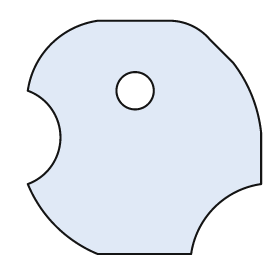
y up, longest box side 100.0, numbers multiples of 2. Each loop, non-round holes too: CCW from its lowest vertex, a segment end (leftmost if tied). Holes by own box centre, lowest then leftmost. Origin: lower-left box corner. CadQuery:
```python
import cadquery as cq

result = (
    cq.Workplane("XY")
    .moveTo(30.0, 0.0)
    .lineTo(70.0, 0.0)
    .threePointArc((80.0, 20.0), (100.0, 30.0))
    .lineTo(100.0, 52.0)
    .threePointArc((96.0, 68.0), (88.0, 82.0))
    .lineTo(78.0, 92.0)
    .threePointArc((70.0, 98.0), (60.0, 100.0))
    .lineTo(30.0, 100.0)
    .threePointArc((10.0, 90.0), (0.0, 70.0))
    .threePointArc((14.0, 50.0), (0.0, 30.0))
    .threePointArc((12.0, 12.0), (30.0, 0.0))
    .close()
    .moveTo(46.0, 70.0)
    .circle(8.0)
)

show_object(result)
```